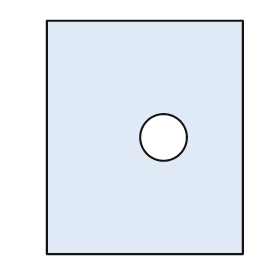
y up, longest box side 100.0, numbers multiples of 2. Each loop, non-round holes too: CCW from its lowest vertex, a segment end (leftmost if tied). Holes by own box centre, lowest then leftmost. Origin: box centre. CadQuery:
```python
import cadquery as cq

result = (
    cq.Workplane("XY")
    .moveTo(-42.0, -50.0)
    .lineTo(42.0, -50.0)
    .lineTo(42.0, 50.0)
    .lineTo(-42.0, 50.0)
    .close()
    .moveTo(8.0, 0.0)
    .circle(10.0)
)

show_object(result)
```